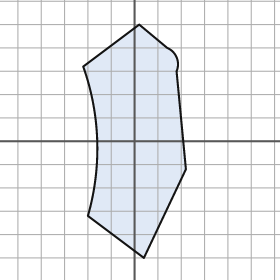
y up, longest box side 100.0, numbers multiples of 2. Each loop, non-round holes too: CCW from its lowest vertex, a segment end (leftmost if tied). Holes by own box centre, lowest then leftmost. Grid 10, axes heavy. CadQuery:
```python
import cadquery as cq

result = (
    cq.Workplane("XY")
    .moveTo(4.0, -50.0)
    .lineTo(22.0, -12.0)
    .lineTo(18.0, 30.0)
    .threePointArc((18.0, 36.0), (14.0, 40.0))
    .lineTo(2.0, 50.0)
    .lineTo(-22.0, 32.0)
    .threePointArc((-16.0, 0.0), (-20.0, -32.0))
    .close()
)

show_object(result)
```